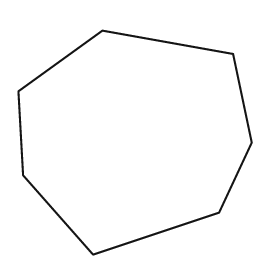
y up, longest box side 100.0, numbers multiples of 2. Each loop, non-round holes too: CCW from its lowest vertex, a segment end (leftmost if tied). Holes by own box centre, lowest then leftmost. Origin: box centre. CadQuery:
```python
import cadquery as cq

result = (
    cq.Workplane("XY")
    .moveTo(-18.0, -48.0)
    .lineTo(36.0, -30.0)
    .lineTo(50.0, 0.0)
    .lineTo(42.0, 38.0)
    .lineTo(-14.0, 48.0)
    .lineTo(-50.0, 22.0)
    .lineTo(-48.0, -14.0)
    .close()
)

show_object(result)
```